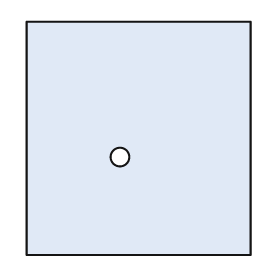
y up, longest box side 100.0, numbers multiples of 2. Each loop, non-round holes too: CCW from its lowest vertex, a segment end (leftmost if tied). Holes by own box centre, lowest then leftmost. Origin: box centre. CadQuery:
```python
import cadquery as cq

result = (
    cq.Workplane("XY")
    .moveTo(-48.0, -50.0)
    .lineTo(48.0, -50.0)
    .lineTo(48.0, 50.0)
    .lineTo(-48.0, 50.0)
    .close()
    .moveTo(-8.0, -8.0)
    .circle(4.0)
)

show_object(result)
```